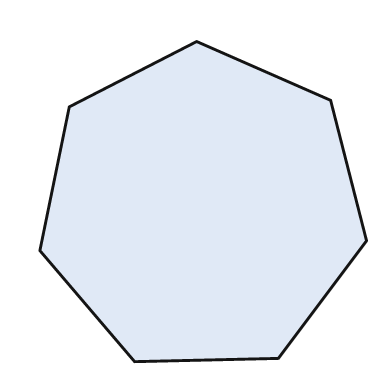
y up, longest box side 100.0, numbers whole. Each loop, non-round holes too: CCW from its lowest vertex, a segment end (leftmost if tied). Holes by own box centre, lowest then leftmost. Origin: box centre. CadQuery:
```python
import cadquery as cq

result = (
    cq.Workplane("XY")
    .moveTo(-21.0, -49.0)
    .lineTo(23.0, -48.0)
    .lineTo(50.0, -12.0)
    .lineTo(39.0, 31.0)
    .lineTo(-2.0, 49.0)
    .lineTo(-41.0, 29.0)
    .lineTo(-50.0, -15.0)
    .close()
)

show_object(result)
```